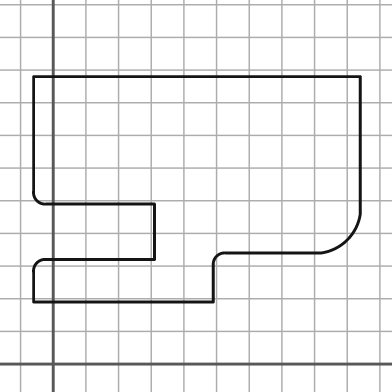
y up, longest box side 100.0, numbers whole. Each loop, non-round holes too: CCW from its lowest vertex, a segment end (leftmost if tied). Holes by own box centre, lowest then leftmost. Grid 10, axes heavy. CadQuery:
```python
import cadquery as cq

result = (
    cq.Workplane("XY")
    .moveTo(-6.0, 19.0)
    .lineTo(49.0, 19.0)
    .lineTo(49.0, 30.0)
    .threePointArc((50.0, 33.0), (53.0, 34.0))
    .lineTo(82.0, 34.0)
    .threePointArc((90.0, 38.0), (94.0, 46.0))
    .lineTo(94.0, 88.0)
    .lineTo(-6.0, 88.0)
    .lineTo(-6.0, 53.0)
    .threePointArc((-5.0, 50.0), (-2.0, 49.0))
    .lineTo(31.0, 49.0)
    .lineTo(31.0, 32.0)
    .lineTo(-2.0, 32.0)
    .threePointArc((-5.0, 31.0), (-6.0, 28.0))
    .close()
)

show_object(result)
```